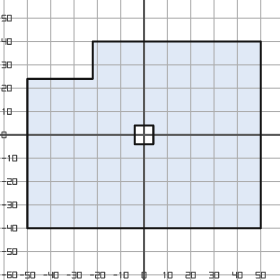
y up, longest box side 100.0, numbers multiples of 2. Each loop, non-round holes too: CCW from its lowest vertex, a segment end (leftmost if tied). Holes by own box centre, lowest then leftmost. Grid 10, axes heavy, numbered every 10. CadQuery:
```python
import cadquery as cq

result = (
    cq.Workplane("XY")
    .moveTo(-50.0, -40.0)
    .lineTo(50.0, -40.0)
    .lineTo(50.0, 40.0)
    .lineTo(-22.0, 40.0)
    .lineTo(-22.0, 24.0)
    .lineTo(-50.0, 24.0)
    .close()
    .moveTo(-4.0, -4.0)
    .lineTo(4.0, -4.0)
    .lineTo(4.0, 4.0)
    .lineTo(-4.0, 4.0)
    .close()
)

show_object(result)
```